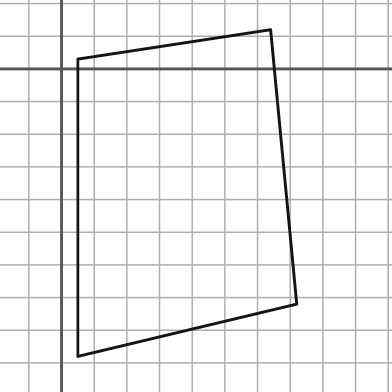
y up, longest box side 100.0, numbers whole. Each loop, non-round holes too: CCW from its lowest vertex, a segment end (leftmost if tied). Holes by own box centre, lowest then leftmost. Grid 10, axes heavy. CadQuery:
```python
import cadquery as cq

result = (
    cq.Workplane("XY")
    .moveTo(5.0, -88.0)
    .lineTo(72.0, -72.0)
    .lineTo(64.0, 12.0)
    .lineTo(5.0, 3.0)
    .close()
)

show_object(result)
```